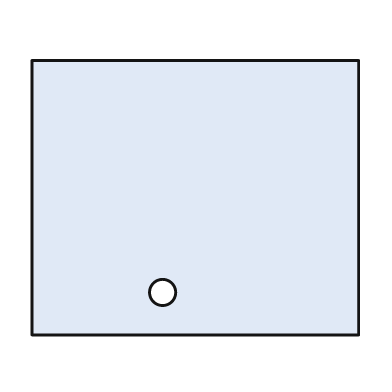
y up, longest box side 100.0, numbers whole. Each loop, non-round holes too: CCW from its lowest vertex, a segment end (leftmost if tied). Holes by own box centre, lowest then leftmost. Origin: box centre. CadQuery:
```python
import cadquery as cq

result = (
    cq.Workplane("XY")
    .moveTo(-50.0, -42.0)
    .lineTo(50.0, -42.0)
    .lineTo(50.0, 42.0)
    .lineTo(-50.0, 42.0)
    .close()
    .moveTo(-10.0, -29.0)
    .circle(4.0)
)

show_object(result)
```